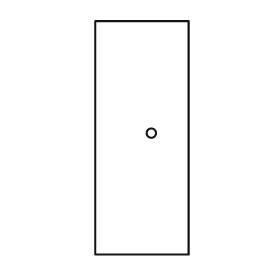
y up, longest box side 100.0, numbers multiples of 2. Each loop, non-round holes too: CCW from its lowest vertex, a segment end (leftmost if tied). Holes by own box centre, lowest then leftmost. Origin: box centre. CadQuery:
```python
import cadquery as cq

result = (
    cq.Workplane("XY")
    .moveTo(-20.0, -50.0)
    .lineTo(20.0, -50.0)
    .lineTo(20.0, 50.0)
    .lineTo(-20.0, 50.0)
    .close()
    .moveTo(4.0, 2.0)
    .circle(2.0)
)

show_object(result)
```